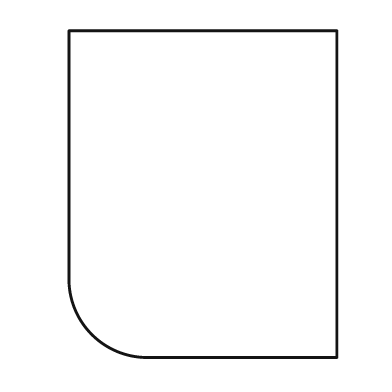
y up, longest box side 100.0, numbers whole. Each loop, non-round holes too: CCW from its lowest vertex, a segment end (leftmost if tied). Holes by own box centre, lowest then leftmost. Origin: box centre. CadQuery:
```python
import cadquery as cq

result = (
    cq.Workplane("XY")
    .moveTo(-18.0, -50.0)
    .lineTo(41.0, -50.0)
    .lineTo(41.0, 50.0)
    .lineTo(-41.0, 50.0)
    .lineTo(-41.0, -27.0)
    .threePointArc((-34.0, -43.0), (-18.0, -50.0))
    .close()
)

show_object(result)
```